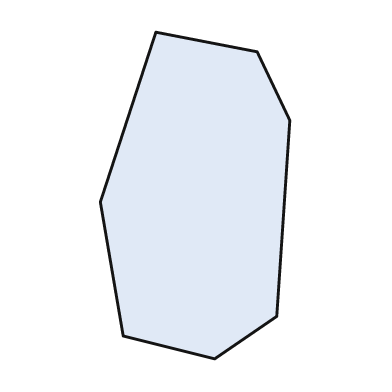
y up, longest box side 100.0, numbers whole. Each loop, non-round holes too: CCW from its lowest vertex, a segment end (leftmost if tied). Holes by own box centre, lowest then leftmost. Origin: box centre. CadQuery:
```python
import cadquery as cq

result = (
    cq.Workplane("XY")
    .moveTo(6.0, -50.0)
    .lineTo(25.0, -37.0)
    .lineTo(29.0, 23.0)
    .lineTo(19.0, 44.0)
    .lineTo(-12.0, 50.0)
    .lineTo(-29.0, -2.0)
    .lineTo(-22.0, -43.0)
    .close()
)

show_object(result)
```